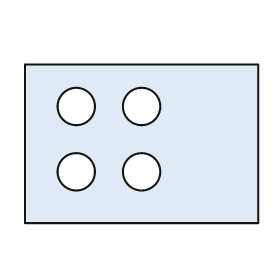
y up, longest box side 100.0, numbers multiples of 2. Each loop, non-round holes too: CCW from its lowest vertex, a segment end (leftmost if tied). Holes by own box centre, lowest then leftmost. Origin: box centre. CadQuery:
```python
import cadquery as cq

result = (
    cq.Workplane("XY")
    .moveTo(-50.0, -34.0)
    .lineTo(50.0, -34.0)
    .lineTo(50.0, 34.0)
    .lineTo(-50.0, 34.0)
    .close()
    .moveTo(-28.0, -12.0)
    .circle(8.0)
    .moveTo(0.0, -12.0)
    .circle(8.0)
    .moveTo(-28.0, 16.0)
    .circle(8.0)
    .moveTo(0.0, 16.0)
    .circle(8.0)
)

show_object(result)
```